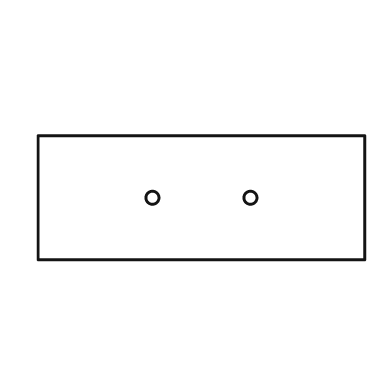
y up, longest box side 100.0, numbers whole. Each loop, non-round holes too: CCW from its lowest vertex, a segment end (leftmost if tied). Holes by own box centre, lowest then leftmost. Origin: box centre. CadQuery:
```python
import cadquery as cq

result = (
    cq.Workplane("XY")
    .moveTo(-50.0, -19.0)
    .lineTo(50.0, -19.0)
    .lineTo(50.0, 19.0)
    .lineTo(-50.0, 19.0)
    .close()
    .moveTo(-15.0, 0.0)
    .circle(2.0)
    .moveTo(15.0, 0.0)
    .circle(2.0)
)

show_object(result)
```